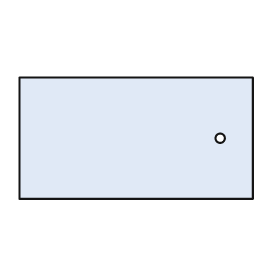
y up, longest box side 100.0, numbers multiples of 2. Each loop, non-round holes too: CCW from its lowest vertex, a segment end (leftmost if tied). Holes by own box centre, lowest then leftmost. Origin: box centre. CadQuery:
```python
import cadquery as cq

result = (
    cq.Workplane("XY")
    .moveTo(-50.0, -26.0)
    .lineTo(50.0, -26.0)
    .lineTo(50.0, 26.0)
    .lineTo(-50.0, 26.0)
    .close()
    .moveTo(36.0, 0.0)
    .circle(2.0)
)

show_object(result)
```